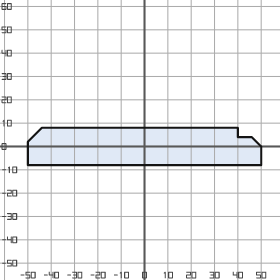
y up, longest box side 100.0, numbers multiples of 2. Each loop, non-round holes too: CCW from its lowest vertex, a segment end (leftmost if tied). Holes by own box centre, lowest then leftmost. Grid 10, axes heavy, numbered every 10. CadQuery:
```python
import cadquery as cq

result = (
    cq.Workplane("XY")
    .moveTo(-50.0, -8.0)
    .lineTo(50.0, -8.0)
    .lineTo(50.0, 0.0)
    .lineTo(46.0, 4.0)
    .lineTo(40.0, 4.0)
    .lineTo(40.0, 8.0)
    .lineTo(-44.0, 8.0)
    .lineTo(-50.0, 2.0)
    .close()
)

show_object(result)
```